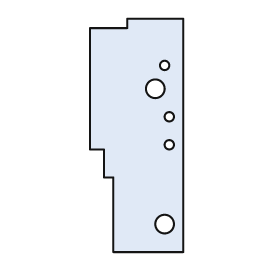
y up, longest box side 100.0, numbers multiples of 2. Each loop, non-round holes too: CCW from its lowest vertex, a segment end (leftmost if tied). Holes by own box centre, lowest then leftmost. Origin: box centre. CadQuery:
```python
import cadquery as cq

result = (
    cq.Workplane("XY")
    .moveTo(-10.0, -50.0)
    .lineTo(20.0, -50.0)
    .lineTo(20.0, 50.0)
    .lineTo(-4.0, 50.0)
    .lineTo(-4.0, 46.0)
    .lineTo(-20.0, 46.0)
    .lineTo(-20.0, -6.0)
    .lineTo(-14.0, -6.0)
    .lineTo(-14.0, -18.0)
    .lineTo(-10.0, -18.0)
    .close()
    .moveTo(12.0, -38.0)
    .circle(4.0)
    .moveTo(14.0, -4.0)
    .circle(2.0)
    .moveTo(14.0, 8.0)
    .circle(2.0)
    .moveTo(8.0, 20.0)
    .circle(4.0)
    .moveTo(12.0, 30.0)
    .circle(2.0)
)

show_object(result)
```